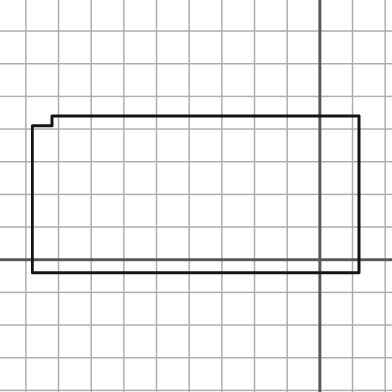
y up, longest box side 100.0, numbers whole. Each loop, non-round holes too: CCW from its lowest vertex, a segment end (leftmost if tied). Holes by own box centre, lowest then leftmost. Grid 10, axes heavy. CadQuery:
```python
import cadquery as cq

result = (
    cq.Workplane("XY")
    .moveTo(-88.0, -4.0)
    .lineTo(12.0, -4.0)
    .lineTo(12.0, 44.0)
    .lineTo(-82.0, 44.0)
    .lineTo(-82.0, 41.0)
    .lineTo(-88.0, 41.0)
    .close()
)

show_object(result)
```